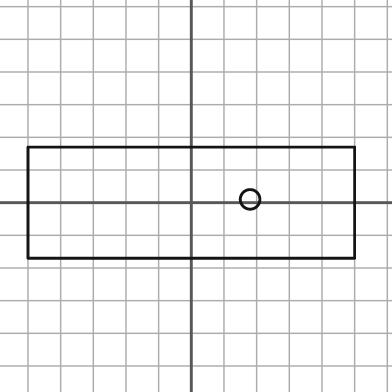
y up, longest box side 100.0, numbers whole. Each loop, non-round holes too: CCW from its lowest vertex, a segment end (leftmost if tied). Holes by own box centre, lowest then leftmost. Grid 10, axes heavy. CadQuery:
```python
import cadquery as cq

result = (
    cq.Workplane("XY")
    .moveTo(-50.0, -17.0)
    .lineTo(50.0, -17.0)
    .lineTo(50.0, 17.0)
    .lineTo(-50.0, 17.0)
    .close()
    .moveTo(18.0, 1.0)
    .circle(3.0)
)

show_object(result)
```